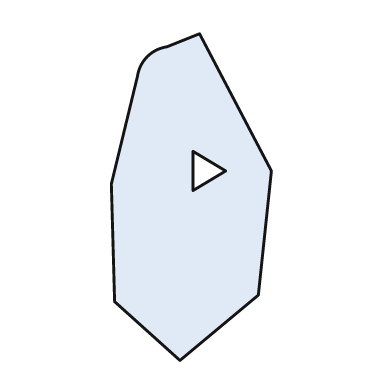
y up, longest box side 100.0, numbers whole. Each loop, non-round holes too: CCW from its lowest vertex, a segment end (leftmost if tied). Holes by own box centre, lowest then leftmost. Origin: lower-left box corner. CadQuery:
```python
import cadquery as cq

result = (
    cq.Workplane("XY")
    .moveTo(21.0, 0.0)
    .lineTo(45.0, 20.0)
    .lineTo(49.0, 58.0)
    .lineTo(27.0, 100.0)
    .lineTo(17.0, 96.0)
    .threePointArc((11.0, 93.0), (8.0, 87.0))
    .lineTo(0.0, 54.0)
    .lineTo(1.0, 18.0)
    .close()
    .moveTo(25.0, 52.0)
    .lineTo(35.0, 58.0)
    .lineTo(25.0, 64.0)
    .close()
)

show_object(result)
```